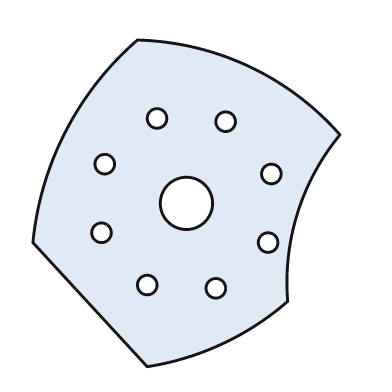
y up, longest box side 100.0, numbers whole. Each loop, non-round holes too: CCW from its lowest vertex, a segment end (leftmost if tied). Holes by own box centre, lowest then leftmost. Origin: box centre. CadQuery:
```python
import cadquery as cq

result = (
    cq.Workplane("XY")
    .moveTo(-12.0, -50.0)
    .threePointArc((11.0, -43.0), (31.0, -30.0))
    .threePointArc((34.0, -3.0), (47.0, 21.0))
    .threePointArc((19.0, 42.0), (-15.0, 50.0))
    .threePointArc((-37.0, 22.0), (-47.0, -12.0))
    .close()
    .moveTo(9.0, -26.0)
    .circle(3.0)
    .moveTo(-12.0, -25.0)
    .circle(3.0)
    .moveTo(25.0, -12.0)
    .circle(3.0)
    .moveTo(-26.0, -9.0)
    .circle(3.0)
    .moveTo(0.0, 0.0)
    .circle(8.0)
    .moveTo(26.0, 9.0)
    .circle(3.0)
    .moveTo(-25.0, 12.0)
    .circle(3.0)
    .moveTo(12.0, 25.0)
    .circle(3.0)
    .moveTo(-9.0, 26.0)
    .circle(3.0)
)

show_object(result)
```